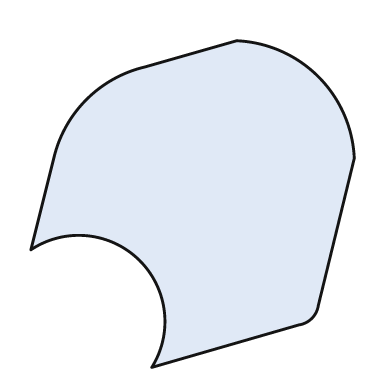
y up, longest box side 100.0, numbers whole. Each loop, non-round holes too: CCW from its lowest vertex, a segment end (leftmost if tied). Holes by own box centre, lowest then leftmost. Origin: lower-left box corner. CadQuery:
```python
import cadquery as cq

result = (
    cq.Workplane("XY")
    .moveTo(37.0, 0.0)
    .lineTo(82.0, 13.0)
    .threePointArc((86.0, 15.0), (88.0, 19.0))
    .lineTo(99.0, 64.0)
    .threePointArc((88.0, 89.0), (63.0, 100.0))
    .lineTo(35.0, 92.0)
    .threePointArc((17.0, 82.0), (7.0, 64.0))
    .lineTo(0.0, 36.0)
    .threePointArc((33.0, 33.0), (37.0, 0.0))
    .close()
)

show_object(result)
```